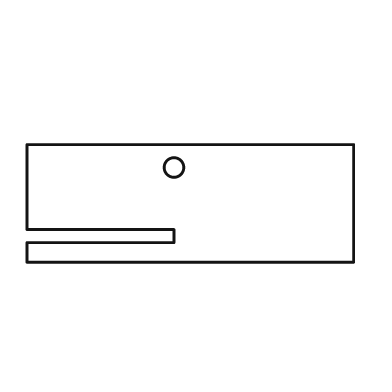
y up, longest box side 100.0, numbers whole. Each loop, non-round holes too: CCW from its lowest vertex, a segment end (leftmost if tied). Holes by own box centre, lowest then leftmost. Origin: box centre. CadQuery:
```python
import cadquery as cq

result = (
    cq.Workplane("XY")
    .moveTo(-50.0, -18.0)
    .lineTo(50.0, -18.0)
    .lineTo(50.0, 18.0)
    .lineTo(-50.0, 18.0)
    .lineTo(-50.0, -8.0)
    .lineTo(-5.0, -8.0)
    .lineTo(-5.0, -12.0)
    .lineTo(-50.0, -12.0)
    .close()
    .moveTo(-5.0, 11.0)
    .circle(3.0)
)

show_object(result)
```